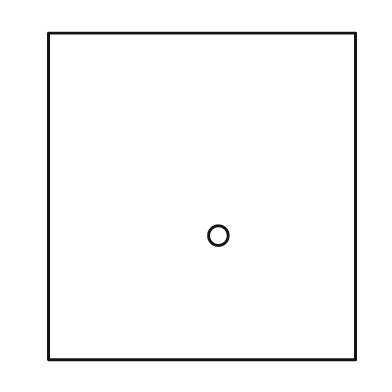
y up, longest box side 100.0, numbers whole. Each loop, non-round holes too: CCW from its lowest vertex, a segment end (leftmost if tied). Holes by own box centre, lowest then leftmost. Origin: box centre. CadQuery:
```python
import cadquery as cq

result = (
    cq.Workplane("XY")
    .moveTo(-47.0, -50.0)
    .lineTo(47.0, -50.0)
    .lineTo(47.0, 50.0)
    .lineTo(-47.0, 50.0)
    .close()
    .moveTo(5.0, -12.0)
    .circle(3.0)
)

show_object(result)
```